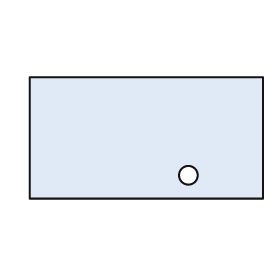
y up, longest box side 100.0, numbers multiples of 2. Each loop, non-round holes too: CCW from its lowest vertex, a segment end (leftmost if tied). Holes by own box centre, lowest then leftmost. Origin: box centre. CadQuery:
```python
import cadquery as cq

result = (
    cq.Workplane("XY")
    .moveTo(-50.0, -26.0)
    .lineTo(50.0, -26.0)
    .lineTo(50.0, 26.0)
    .lineTo(-50.0, 26.0)
    .close()
    .moveTo(18.0, -16.0)
    .circle(4.0)
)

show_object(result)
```